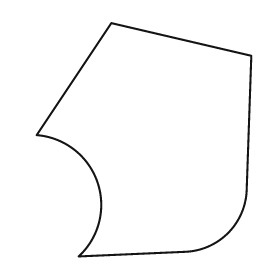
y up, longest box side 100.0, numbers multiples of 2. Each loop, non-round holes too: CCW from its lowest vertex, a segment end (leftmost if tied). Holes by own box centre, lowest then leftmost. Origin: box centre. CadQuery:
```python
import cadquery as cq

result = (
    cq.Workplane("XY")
    .moveTo(-28.0, -50.0)
    .lineTo(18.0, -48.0)
    .threePointArc((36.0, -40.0), (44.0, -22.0))
    .lineTo(46.0, 36.0)
    .lineTo(-14.0, 50.0)
    .lineTo(-46.0, 2.0)
    .threePointArc((-20.0, -18.0), (-28.0, -50.0))
    .close()
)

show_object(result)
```